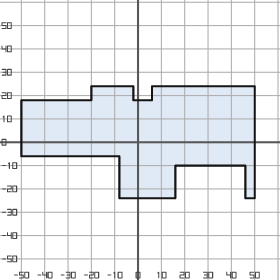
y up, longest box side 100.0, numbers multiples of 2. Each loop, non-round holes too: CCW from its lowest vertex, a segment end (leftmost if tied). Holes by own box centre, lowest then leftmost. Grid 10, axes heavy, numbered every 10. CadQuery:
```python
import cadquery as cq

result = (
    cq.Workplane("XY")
    .moveTo(-8.0, -24.0)
    .lineTo(16.0, -24.0)
    .lineTo(16.0, -10.0)
    .lineTo(46.0, -10.0)
    .lineTo(46.0, -24.0)
    .lineTo(50.0, -24.0)
    .lineTo(50.0, 24.0)
    .lineTo(6.0, 24.0)
    .lineTo(6.0, 18.0)
    .lineTo(-2.0, 18.0)
    .lineTo(-2.0, 24.0)
    .lineTo(-20.0, 24.0)
    .lineTo(-20.0, 18.0)
    .lineTo(-50.0, 18.0)
    .lineTo(-50.0, -6.0)
    .lineTo(-8.0, -6.0)
    .close()
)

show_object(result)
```